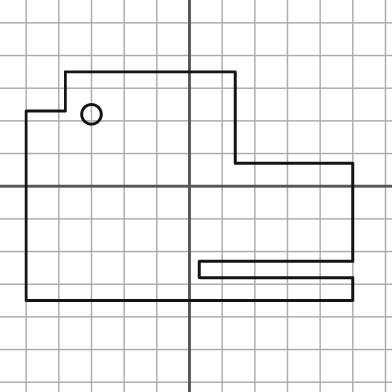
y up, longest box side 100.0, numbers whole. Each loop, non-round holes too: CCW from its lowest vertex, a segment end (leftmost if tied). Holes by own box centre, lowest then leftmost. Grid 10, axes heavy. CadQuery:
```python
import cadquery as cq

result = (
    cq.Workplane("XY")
    .moveTo(-50.0, -35.0)
    .lineTo(50.0, -35.0)
    .lineTo(50.0, -28.0)
    .lineTo(3.0, -28.0)
    .lineTo(3.0, -23.0)
    .lineTo(50.0, -23.0)
    .lineTo(50.0, 7.0)
    .lineTo(14.0, 7.0)
    .lineTo(14.0, 35.0)
    .lineTo(-38.0, 35.0)
    .lineTo(-38.0, 23.0)
    .lineTo(-50.0, 23.0)
    .close()
    .moveTo(-30.0, 22.0)
    .circle(3.0)
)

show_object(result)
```